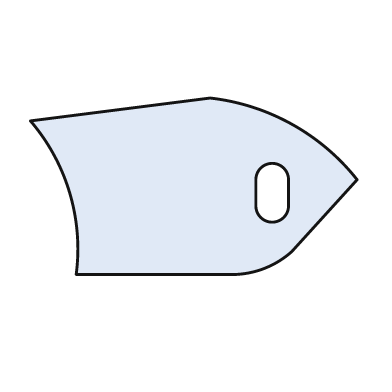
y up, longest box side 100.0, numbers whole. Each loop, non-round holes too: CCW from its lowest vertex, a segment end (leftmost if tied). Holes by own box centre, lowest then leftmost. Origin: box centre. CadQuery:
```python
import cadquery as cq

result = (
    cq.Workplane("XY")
    .moveTo(-36.0, -27.0)
    .lineTo(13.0, -27.0)
    .threePointArc((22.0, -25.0), (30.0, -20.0))
    .lineTo(50.0, 2.0)
    .threePointArc((30.0, 19.0), (5.0, 27.0))
    .lineTo(-50.0, 20.0)
    .threePointArc((-38.0, -2.0), (-36.0, -27.0))
    .close()
    .moveTo(19.0, -6.0)
    .threePointArc((24.0, -11.0), (29.0, -6.0))
    .lineTo(29.0, 2.0)
    .threePointArc((24.0, 7.0), (19.0, 2.0))
    .close()
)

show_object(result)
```